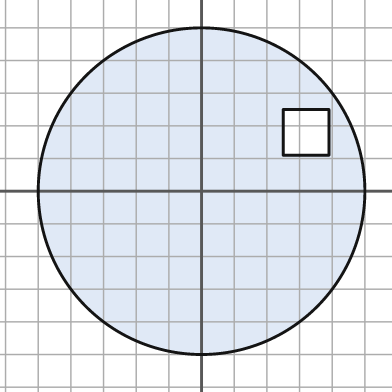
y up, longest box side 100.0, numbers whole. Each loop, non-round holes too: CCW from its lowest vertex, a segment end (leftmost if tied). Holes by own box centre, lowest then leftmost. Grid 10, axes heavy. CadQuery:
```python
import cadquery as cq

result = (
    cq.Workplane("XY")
    .moveTo(0.0, 0.0)
    .circle(50.0)
    .moveTo(25.0, 11.0)
    .lineTo(39.0, 11.0)
    .lineTo(39.0, 25.0)
    .lineTo(25.0, 25.0)
    .close()
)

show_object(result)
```